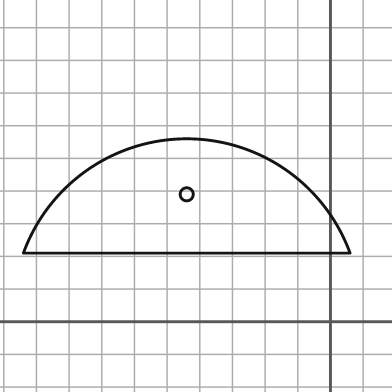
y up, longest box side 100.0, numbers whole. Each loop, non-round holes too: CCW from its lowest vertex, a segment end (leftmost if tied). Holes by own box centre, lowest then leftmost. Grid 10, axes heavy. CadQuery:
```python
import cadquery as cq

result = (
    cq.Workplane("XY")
    .moveTo(-94.0, 21.0)
    .lineTo(6.0, 21.0)
    .threePointArc((-44.0, 56.0), (-94.0, 21.0))
    .close()
    .moveTo(-44.0, 39.0)
    .circle(2.0)
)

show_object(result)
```